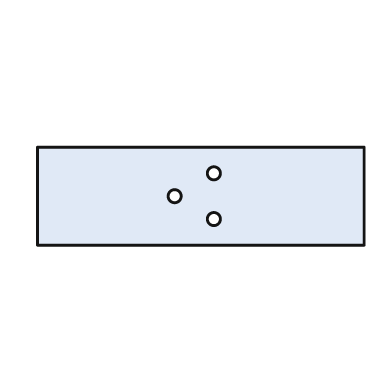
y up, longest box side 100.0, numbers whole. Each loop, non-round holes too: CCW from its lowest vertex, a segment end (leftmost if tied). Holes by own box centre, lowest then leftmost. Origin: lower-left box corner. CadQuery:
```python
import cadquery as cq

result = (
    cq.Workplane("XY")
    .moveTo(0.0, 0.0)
    .lineTo(100.0, 0.0)
    .lineTo(100.0, 30.0)
    .lineTo(0.0, 30.0)
    .close()
    .moveTo(54.0, 8.0)
    .circle(2.0)
    .moveTo(42.0, 15.0)
    .circle(2.0)
    .moveTo(54.0, 22.0)
    .circle(2.0)
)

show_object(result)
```